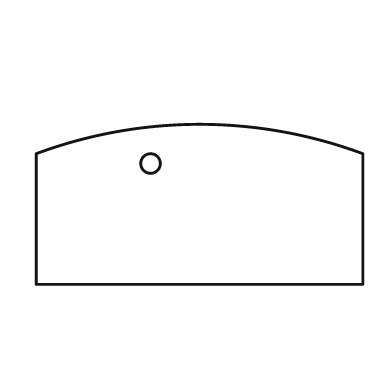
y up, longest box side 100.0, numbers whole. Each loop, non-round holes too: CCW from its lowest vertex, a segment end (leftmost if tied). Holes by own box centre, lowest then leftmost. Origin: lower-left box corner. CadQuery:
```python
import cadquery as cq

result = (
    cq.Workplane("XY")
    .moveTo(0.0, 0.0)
    .lineTo(100.0, 0.0)
    .lineTo(100.0, 40.0)
    .threePointArc((50.0, 49.0), (0.0, 40.0))
    .close()
    .moveTo(35.0, 37.0)
    .circle(3.0)
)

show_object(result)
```